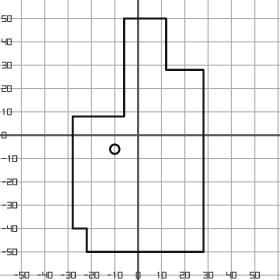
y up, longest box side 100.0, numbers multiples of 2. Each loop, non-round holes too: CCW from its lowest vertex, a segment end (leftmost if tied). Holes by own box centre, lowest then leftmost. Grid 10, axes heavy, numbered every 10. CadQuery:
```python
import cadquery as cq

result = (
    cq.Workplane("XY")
    .moveTo(-22.0, -50.0)
    .lineTo(28.0, -50.0)
    .lineTo(28.0, 28.0)
    .lineTo(12.0, 28.0)
    .lineTo(12.0, 50.0)
    .lineTo(-6.0, 50.0)
    .lineTo(-6.0, 8.0)
    .lineTo(-28.0, 8.0)
    .lineTo(-28.0, -40.0)
    .lineTo(-22.0, -40.0)
    .close()
    .moveTo(-10.0, -6.0)
    .circle(2.0)
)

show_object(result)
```